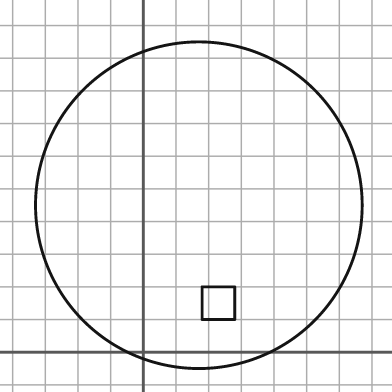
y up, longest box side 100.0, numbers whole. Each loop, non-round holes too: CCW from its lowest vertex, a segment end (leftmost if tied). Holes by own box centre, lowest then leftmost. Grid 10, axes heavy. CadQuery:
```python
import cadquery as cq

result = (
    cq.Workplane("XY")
    .moveTo(17.0, 45.0)
    .circle(50.0)
    .moveTo(18.0, 10.0)
    .lineTo(28.0, 10.0)
    .lineTo(28.0, 20.0)
    .lineTo(18.0, 20.0)
    .close()
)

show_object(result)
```